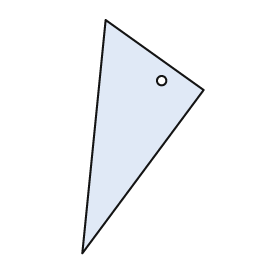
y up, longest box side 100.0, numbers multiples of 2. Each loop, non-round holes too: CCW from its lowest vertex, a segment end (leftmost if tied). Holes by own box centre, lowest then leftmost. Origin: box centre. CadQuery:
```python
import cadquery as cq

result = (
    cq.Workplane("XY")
    .moveTo(-26.0, -50.0)
    .lineTo(26.0, 20.0)
    .lineTo(-16.0, 50.0)
    .close()
    .moveTo(8.0, 24.0)
    .circle(2.0)
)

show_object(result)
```